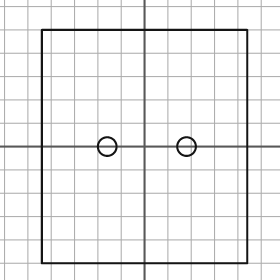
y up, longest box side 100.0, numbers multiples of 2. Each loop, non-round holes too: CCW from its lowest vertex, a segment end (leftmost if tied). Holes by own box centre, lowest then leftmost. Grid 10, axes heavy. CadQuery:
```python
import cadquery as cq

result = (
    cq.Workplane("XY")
    .moveTo(-44.0, -50.0)
    .lineTo(44.0, -50.0)
    .lineTo(44.0, 50.0)
    .lineTo(-44.0, 50.0)
    .close()
    .moveTo(-16.0, 0.0)
    .circle(4.0)
    .moveTo(18.0, 0.0)
    .circle(4.0)
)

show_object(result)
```